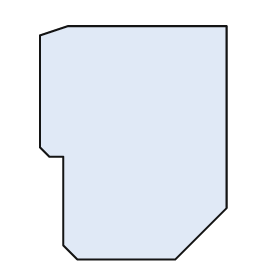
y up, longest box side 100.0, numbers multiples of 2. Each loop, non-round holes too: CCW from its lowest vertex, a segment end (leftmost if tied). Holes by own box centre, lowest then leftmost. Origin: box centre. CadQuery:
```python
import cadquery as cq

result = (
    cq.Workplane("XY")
    .moveTo(-24.0, -50.0)
    .lineTo(18.0, -50.0)
    .lineTo(40.0, -28.0)
    .lineTo(40.0, 50.0)
    .lineTo(-28.0, 50.0)
    .lineTo(-40.0, 46.0)
    .lineTo(-40.0, -2.0)
    .lineTo(-36.0, -6.0)
    .lineTo(-30.0, -6.0)
    .lineTo(-30.0, -44.0)
    .close()
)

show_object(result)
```